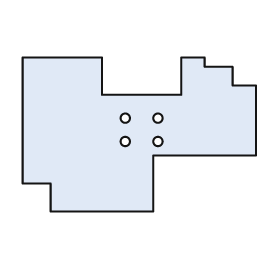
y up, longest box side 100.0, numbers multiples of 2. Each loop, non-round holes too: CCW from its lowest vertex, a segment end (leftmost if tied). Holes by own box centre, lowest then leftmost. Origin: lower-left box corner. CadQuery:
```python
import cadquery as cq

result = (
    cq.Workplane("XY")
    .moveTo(12.0, 0.0)
    .lineTo(56.0, 0.0)
    .lineTo(56.0, 24.0)
    .lineTo(100.0, 24.0)
    .lineTo(100.0, 54.0)
    .lineTo(90.0, 54.0)
    .lineTo(90.0, 62.0)
    .lineTo(78.0, 62.0)
    .lineTo(78.0, 66.0)
    .lineTo(68.0, 66.0)
    .lineTo(68.0, 50.0)
    .lineTo(34.0, 50.0)
    .lineTo(34.0, 66.0)
    .lineTo(0.0, 66.0)
    .lineTo(0.0, 12.0)
    .lineTo(12.0, 12.0)
    .close()
    .moveTo(44.0, 30.0)
    .circle(2.0)
    .moveTo(58.0, 30.0)
    .circle(2.0)
    .moveTo(44.0, 40.0)
    .circle(2.0)
    .moveTo(58.0, 40.0)
    .circle(2.0)
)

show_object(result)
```